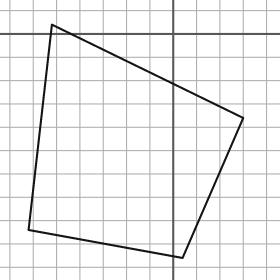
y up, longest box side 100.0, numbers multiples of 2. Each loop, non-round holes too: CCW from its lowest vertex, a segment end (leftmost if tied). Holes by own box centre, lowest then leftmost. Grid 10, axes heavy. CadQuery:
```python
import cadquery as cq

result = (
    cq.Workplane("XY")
    .moveTo(4.0, -96.0)
    .lineTo(30.0, -36.0)
    .lineTo(-52.0, 4.0)
    .lineTo(-62.0, -84.0)
    .close()
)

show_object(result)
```